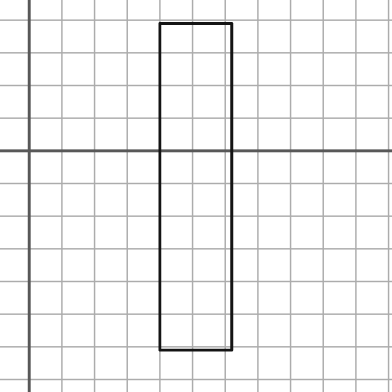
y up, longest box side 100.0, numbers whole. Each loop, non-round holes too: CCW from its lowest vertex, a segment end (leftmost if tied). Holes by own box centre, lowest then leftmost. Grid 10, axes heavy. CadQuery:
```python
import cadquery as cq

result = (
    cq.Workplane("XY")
    .moveTo(40.0, -61.0)
    .lineTo(62.0, -61.0)
    .lineTo(62.0, 39.0)
    .lineTo(40.0, 39.0)
    .close()
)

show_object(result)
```